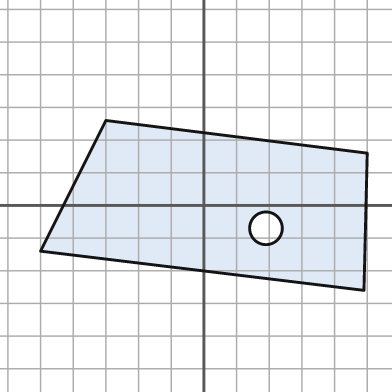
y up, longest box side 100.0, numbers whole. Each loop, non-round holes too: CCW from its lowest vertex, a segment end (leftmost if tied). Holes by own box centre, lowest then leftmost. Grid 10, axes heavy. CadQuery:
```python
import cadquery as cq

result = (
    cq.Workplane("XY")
    .moveTo(49.0, -26.0)
    .lineTo(50.0, 16.0)
    .lineTo(-30.0, 26.0)
    .lineTo(-50.0, -14.0)
    .close()
    .moveTo(19.0, -7.0)
    .circle(5.0)
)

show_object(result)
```